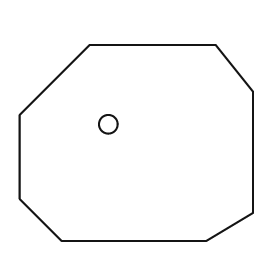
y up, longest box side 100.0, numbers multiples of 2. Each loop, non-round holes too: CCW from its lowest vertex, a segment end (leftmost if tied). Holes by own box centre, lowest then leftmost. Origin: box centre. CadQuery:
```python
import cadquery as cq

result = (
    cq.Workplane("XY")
    .moveTo(-32.0, -42.0)
    .lineTo(30.0, -42.0)
    .lineTo(50.0, -30.0)
    .lineTo(50.0, 22.0)
    .lineTo(34.0, 42.0)
    .lineTo(-20.0, 42.0)
    .lineTo(-50.0, 12.0)
    .lineTo(-50.0, -24.0)
    .close()
    .moveTo(-12.0, 8.0)
    .circle(4.0)
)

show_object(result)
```